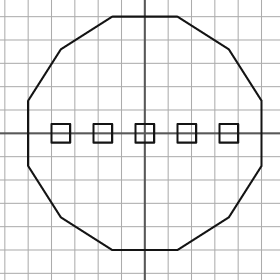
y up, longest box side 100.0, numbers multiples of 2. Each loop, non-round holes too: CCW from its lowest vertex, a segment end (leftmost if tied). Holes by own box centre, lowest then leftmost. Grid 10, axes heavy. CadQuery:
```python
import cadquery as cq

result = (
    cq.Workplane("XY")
    .moveTo(-14.0, -50.0)
    .lineTo(14.0, -50.0)
    .lineTo(36.0, -36.0)
    .lineTo(50.0, -14.0)
    .lineTo(50.0, 14.0)
    .lineTo(36.0, 36.0)
    .lineTo(14.0, 50.0)
    .lineTo(-14.0, 50.0)
    .lineTo(-36.0, 36.0)
    .lineTo(-50.0, 14.0)
    .lineTo(-50.0, -14.0)
    .lineTo(-36.0, -36.0)
    .close()
    .moveTo(-40.0, -4.0)
    .lineTo(-32.0, -4.0)
    .lineTo(-32.0, 4.0)
    .lineTo(-40.0, 4.0)
    .close()
    .moveTo(-22.0, -4.0)
    .lineTo(-14.0, -4.0)
    .lineTo(-14.0, 4.0)
    .lineTo(-22.0, 4.0)
    .close()
    .moveTo(-4.0, -4.0)
    .lineTo(4.0, -4.0)
    .lineTo(4.0, 4.0)
    .lineTo(-4.0, 4.0)
    .close()
    .moveTo(14.0, -4.0)
    .lineTo(22.0, -4.0)
    .lineTo(22.0, 4.0)
    .lineTo(14.0, 4.0)
    .close()
    .moveTo(32.0, -4.0)
    .lineTo(40.0, -4.0)
    .lineTo(40.0, 4.0)
    .lineTo(32.0, 4.0)
    .close()
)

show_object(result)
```